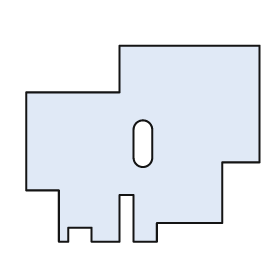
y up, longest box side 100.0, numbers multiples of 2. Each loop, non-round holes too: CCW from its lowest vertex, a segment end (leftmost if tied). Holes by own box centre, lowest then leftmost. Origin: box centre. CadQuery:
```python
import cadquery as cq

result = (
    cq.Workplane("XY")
    .moveTo(-36.0, -42.0)
    .lineTo(-32.0, -42.0)
    .lineTo(-32.0, -36.0)
    .lineTo(-22.0, -36.0)
    .lineTo(-22.0, -42.0)
    .lineTo(-10.0, -42.0)
    .lineTo(-10.0, -22.0)
    .lineTo(-4.0, -22.0)
    .lineTo(-4.0, -42.0)
    .lineTo(6.0, -42.0)
    .lineTo(6.0, -34.0)
    .lineTo(34.0, -34.0)
    .lineTo(34.0, -8.0)
    .lineTo(50.0, -8.0)
    .lineTo(50.0, 42.0)
    .lineTo(-10.0, 42.0)
    .lineTo(-10.0, 22.0)
    .lineTo(-50.0, 22.0)
    .lineTo(-50.0, -20.0)
    .lineTo(-36.0, -20.0)
    .close()
    .moveTo(-4.0, -6.0)
    .threePointArc((0.0, -10.0), (4.0, -6.0))
    .lineTo(4.0, 6.0)
    .threePointArc((0.0, 10.0), (-4.0, 6.0))
    .close()
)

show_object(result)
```